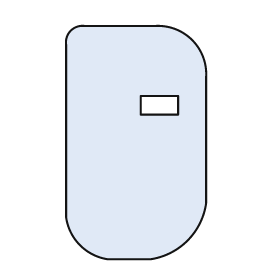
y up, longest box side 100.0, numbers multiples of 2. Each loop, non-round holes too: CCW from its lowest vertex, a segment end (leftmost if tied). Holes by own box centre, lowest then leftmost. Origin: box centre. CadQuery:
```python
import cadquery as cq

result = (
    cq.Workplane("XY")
    .moveTo(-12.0, -50.0)
    .lineTo(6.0, -50.0)
    .threePointArc((22.0, -42.0), (30.0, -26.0))
    .lineTo(30.0, 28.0)
    .threePointArc((24.0, 44.0), (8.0, 50.0))
    .lineTo(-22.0, 50.0)
    .threePointArc((-28.0, 48.0), (-30.0, 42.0))
    .lineTo(-30.0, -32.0)
    .threePointArc((-24.0, -44.0), (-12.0, -50.0))
    .close()
    .moveTo(2.0, 12.0)
    .lineTo(18.0, 12.0)
    .lineTo(18.0, 20.0)
    .lineTo(2.0, 20.0)
    .close()
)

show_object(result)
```